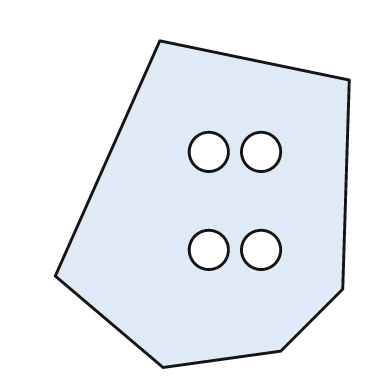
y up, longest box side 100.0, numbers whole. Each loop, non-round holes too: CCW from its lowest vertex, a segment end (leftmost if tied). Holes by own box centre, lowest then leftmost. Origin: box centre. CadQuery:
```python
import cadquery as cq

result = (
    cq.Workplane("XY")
    .moveTo(-12.0, -50.0)
    .lineTo(24.0, -45.0)
    .lineTo(43.0, -26.0)
    .lineTo(45.0, 38.0)
    .lineTo(-13.0, 50.0)
    .lineTo(-45.0, -22.0)
    .close()
    .moveTo(2.0, -14.0)
    .circle(6.0)
    .moveTo(18.0, -14.0)
    .circle(6.0)
    .moveTo(2.0, 16.0)
    .circle(6.0)
    .moveTo(18.0, 16.0)
    .circle(6.0)
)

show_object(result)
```